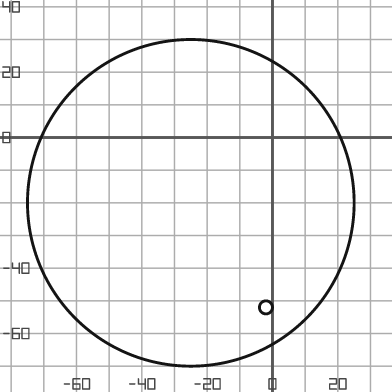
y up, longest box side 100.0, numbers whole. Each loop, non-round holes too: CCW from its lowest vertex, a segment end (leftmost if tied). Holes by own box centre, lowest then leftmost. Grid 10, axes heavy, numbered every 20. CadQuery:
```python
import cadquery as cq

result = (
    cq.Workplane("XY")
    .moveTo(-25.0, -20.0)
    .circle(50.0)
    .moveTo(-2.0, -52.0)
    .circle(2.0)
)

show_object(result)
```